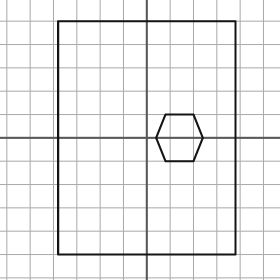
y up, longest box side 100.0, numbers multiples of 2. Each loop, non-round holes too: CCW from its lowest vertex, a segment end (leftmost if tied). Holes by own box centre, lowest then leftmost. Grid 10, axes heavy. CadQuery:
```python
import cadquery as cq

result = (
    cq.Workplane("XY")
    .moveTo(-38.0, -50.0)
    .lineTo(38.0, -50.0)
    .lineTo(38.0, 50.0)
    .lineTo(-38.0, 50.0)
    .close()
    .moveTo(8.0, -10.0)
    .lineTo(20.0, -10.0)
    .lineTo(24.0, 0.0)
    .lineTo(20.0, 10.0)
    .lineTo(8.0, 10.0)
    .lineTo(4.0, 0.0)
    .close()
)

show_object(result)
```